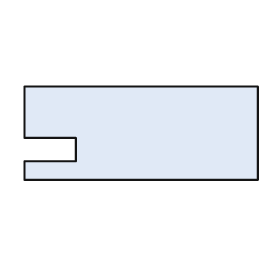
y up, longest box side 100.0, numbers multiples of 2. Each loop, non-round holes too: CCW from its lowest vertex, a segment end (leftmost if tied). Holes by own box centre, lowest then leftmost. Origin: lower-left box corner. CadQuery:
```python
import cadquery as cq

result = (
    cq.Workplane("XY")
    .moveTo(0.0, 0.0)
    .lineTo(100.0, 0.0)
    .lineTo(100.0, 40.0)
    .lineTo(0.0, 40.0)
    .lineTo(0.0, 18.0)
    .lineTo(22.0, 18.0)
    .lineTo(22.0, 8.0)
    .lineTo(0.0, 8.0)
    .close()
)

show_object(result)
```